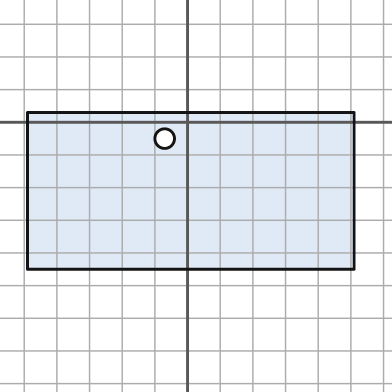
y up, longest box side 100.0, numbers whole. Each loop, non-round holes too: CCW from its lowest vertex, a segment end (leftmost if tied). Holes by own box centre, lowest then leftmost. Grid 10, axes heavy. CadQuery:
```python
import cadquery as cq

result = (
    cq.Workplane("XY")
    .moveTo(-49.0, -45.0)
    .lineTo(51.0, -45.0)
    .lineTo(51.0, 3.0)
    .lineTo(-49.0, 3.0)
    .close()
    .moveTo(-7.0, -5.0)
    .circle(3.0)
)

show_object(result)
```